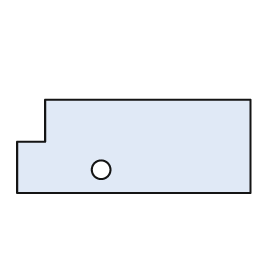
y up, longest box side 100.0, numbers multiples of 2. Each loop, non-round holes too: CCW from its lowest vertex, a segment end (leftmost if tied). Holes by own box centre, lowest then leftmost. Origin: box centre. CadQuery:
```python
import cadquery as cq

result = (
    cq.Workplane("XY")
    .moveTo(-50.0, -20.0)
    .lineTo(50.0, -20.0)
    .lineTo(50.0, 20.0)
    .lineTo(-38.0, 20.0)
    .lineTo(-38.0, 2.0)
    .lineTo(-50.0, 2.0)
    .close()
    .moveTo(-14.0, -10.0)
    .circle(4.0)
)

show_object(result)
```